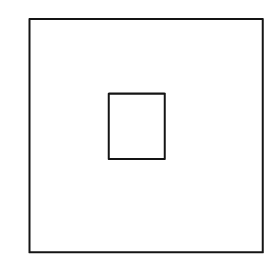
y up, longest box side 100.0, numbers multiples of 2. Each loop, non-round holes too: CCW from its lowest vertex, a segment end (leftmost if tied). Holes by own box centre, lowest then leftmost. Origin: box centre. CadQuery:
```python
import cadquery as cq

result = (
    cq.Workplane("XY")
    .moveTo(-50.0, -50.0)
    .lineTo(50.0, -50.0)
    .lineTo(50.0, 50.0)
    .lineTo(-50.0, 50.0)
    .close()
    .moveTo(-16.0, -10.0)
    .lineTo(8.0, -10.0)
    .lineTo(8.0, 18.0)
    .lineTo(-16.0, 18.0)
    .close()
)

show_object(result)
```